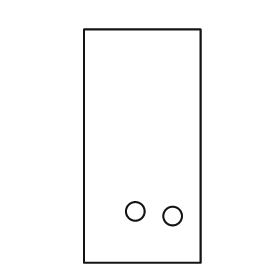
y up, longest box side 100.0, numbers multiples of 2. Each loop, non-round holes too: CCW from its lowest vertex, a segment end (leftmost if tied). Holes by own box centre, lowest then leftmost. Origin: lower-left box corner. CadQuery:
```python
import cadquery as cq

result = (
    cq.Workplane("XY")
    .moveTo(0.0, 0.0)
    .lineTo(50.0, 0.0)
    .lineTo(50.0, 100.0)
    .lineTo(0.0, 100.0)
    .close()
    .moveTo(38.0, 20.0)
    .circle(4.0)
    .moveTo(22.0, 22.0)
    .circle(4.0)
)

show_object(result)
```